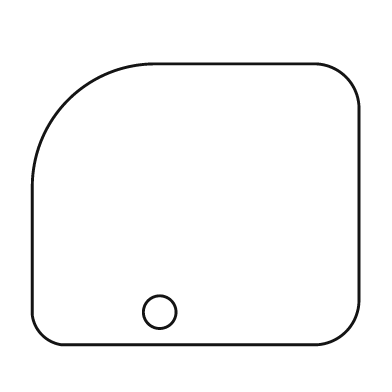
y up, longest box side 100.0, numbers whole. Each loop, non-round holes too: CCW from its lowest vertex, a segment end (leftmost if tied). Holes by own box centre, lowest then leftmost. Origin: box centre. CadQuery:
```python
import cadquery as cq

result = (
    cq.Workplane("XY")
    .moveTo(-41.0, -43.0)
    .lineTo(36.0, -43.0)
    .threePointArc((46.0, -39.0), (50.0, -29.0))
    .lineTo(50.0, 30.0)
    .threePointArc((46.0, 39.0), (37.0, 43.0))
    .lineTo(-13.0, 43.0)
    .threePointArc((-39.0, 32.0), (-50.0, 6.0))
    .lineTo(-50.0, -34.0)
    .threePointArc((-47.0, -40.0), (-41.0, -43.0))
    .close()
    .moveTo(-11.0, -33.0)
    .circle(5.0)
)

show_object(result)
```